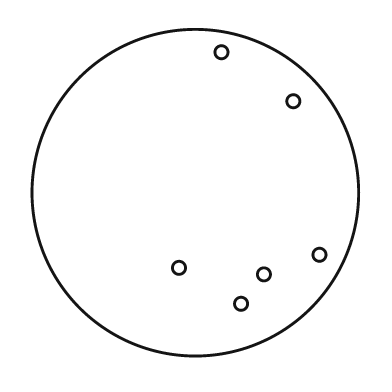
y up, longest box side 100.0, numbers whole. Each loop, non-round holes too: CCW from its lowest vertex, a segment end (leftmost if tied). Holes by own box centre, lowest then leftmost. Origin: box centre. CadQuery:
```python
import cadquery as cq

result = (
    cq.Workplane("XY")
    .moveTo(0.0, 0.0)
    .circle(50.0)
    .moveTo(14.0, -34.0)
    .circle(2.0)
    .moveTo(21.0, -25.0)
    .circle(2.0)
    .moveTo(-5.0, -23.0)
    .circle(2.0)
    .moveTo(38.0, -19.0)
    .circle(2.0)
    .moveTo(30.0, 28.0)
    .circle(2.0)
    .moveTo(8.0, 43.0)
    .circle(2.0)
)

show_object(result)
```